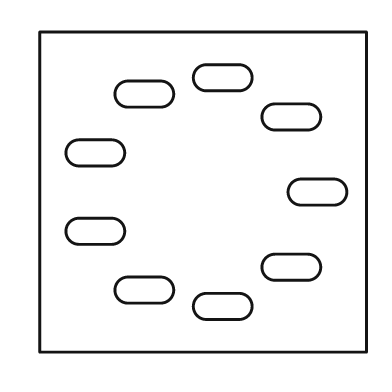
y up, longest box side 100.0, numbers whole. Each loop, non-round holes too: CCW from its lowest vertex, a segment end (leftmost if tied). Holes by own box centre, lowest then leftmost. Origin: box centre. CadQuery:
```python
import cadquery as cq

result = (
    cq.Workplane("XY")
    .moveTo(-50.0, -49.0)
    .lineTo(50.0, -49.0)
    .lineTo(50.0, 49.0)
    .lineTo(-50.0, 49.0)
    .close()
    .moveTo(1.0, -39.0)
    .lineTo(11.0, -39.0)
    .threePointArc((15.0, -35.0), (11.0, -31.0))
    .lineTo(1.0, -31.0)
    .threePointArc((-3.0, -35.0), (1.0, -39.0))
    .close()
    .moveTo(-23.0, -34.0)
    .lineTo(-13.0, -34.0)
    .threePointArc((-9.0, -30.0), (-13.0, -26.0))
    .lineTo(-23.0, -26.0)
    .threePointArc((-27.0, -30.0), (-23.0, -34.0))
    .close()
    .moveTo(22.0, -27.0)
    .lineTo(32.0, -27.0)
    .threePointArc((36.0, -23.0), (32.0, -19.0))
    .lineTo(22.0, -19.0)
    .threePointArc((18.0, -23.0), (22.0, -27.0))
    .close()
    .moveTo(-38.0, -16.0)
    .lineTo(-28.0, -16.0)
    .threePointArc((-24.0, -12.0), (-28.0, -8.0))
    .lineTo(-38.0, -8.0)
    .threePointArc((-42.0, -12.0), (-38.0, -16.0))
    .close()
    .moveTo(30.0, -4.0)
    .lineTo(40.0, -4.0)
    .threePointArc((44.0, 0.0), (40.0, 4.0))
    .lineTo(30.0, 4.0)
    .threePointArc((26.0, 0.0), (30.0, -4.0))
    .close()
    .moveTo(-38.0, 8.0)
    .lineTo(-28.0, 8.0)
    .threePointArc((-24.0, 12.0), (-28.0, 16.0))
    .lineTo(-38.0, 16.0)
    .threePointArc((-42.0, 12.0), (-38.0, 8.0))
    .close()
    .moveTo(22.0, 19.0)
    .lineTo(32.0, 19.0)
    .threePointArc((36.0, 23.0), (32.0, 27.0))
    .lineTo(22.0, 27.0)
    .threePointArc((18.0, 23.0), (22.0, 19.0))
    .close()
    .moveTo(-23.0, 26.0)
    .lineTo(-13.0, 26.0)
    .threePointArc((-9.0, 30.0), (-13.0, 34.0))
    .lineTo(-23.0, 34.0)
    .threePointArc((-27.0, 30.0), (-23.0, 26.0))
    .close()
    .moveTo(1.0, 31.0)
    .lineTo(11.0, 31.0)
    .threePointArc((15.0, 35.0), (11.0, 39.0))
    .lineTo(1.0, 39.0)
    .threePointArc((-3.0, 35.0), (1.0, 31.0))
    .close()
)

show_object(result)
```